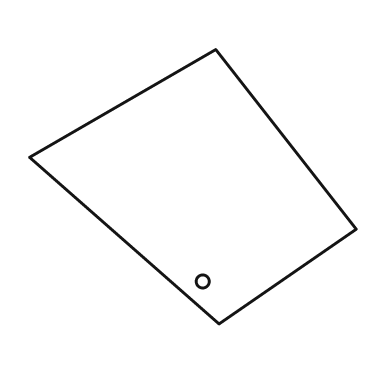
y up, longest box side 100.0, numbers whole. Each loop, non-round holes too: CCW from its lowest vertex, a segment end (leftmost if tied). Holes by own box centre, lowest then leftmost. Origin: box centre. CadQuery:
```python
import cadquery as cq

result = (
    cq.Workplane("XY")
    .moveTo(8.0, -42.0)
    .lineTo(50.0, -13.0)
    .lineTo(7.0, 42.0)
    .lineTo(-50.0, 9.0)
    .close()
    .moveTo(3.0, -29.0)
    .circle(2.0)
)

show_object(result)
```